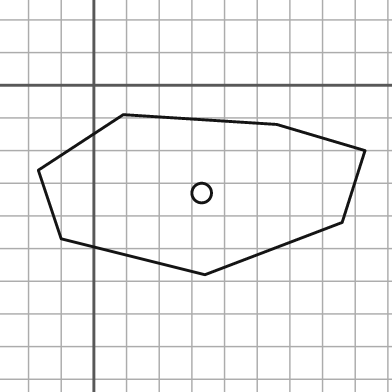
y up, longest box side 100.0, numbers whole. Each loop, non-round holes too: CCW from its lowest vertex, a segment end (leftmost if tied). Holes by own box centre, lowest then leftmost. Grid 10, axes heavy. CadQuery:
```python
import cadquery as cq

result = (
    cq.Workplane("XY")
    .moveTo(34.0, -58.0)
    .lineTo(76.0, -42.0)
    .lineTo(83.0, -20.0)
    .lineTo(56.0, -12.0)
    .lineTo(9.0, -9.0)
    .lineTo(-17.0, -26.0)
    .lineTo(-10.0, -47.0)
    .close()
    .moveTo(33.0, -33.0)
    .circle(3.0)
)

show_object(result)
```